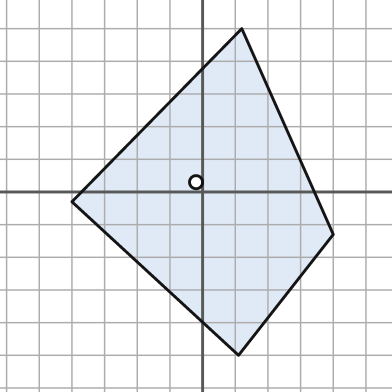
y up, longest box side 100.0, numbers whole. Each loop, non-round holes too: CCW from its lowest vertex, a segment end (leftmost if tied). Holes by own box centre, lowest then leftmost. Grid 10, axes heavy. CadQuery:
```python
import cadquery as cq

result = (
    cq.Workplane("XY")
    .moveTo(11.0, -50.0)
    .lineTo(40.0, -13.0)
    .lineTo(12.0, 50.0)
    .lineTo(-40.0, -3.0)
    .close()
    .moveTo(-2.0, 3.0)
    .circle(2.0)
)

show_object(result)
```